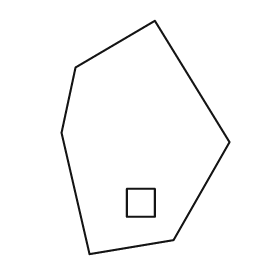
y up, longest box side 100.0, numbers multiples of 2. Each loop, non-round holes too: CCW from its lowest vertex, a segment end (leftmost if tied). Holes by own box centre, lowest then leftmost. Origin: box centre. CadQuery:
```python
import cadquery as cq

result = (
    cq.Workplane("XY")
    .moveTo(-24.0, -50.0)
    .lineTo(12.0, -44.0)
    .lineTo(36.0, -2.0)
    .lineTo(4.0, 50.0)
    .lineTo(-30.0, 30.0)
    .lineTo(-36.0, 2.0)
    .close()
    .moveTo(-8.0, -34.0)
    .lineTo(4.0, -34.0)
    .lineTo(4.0, -22.0)
    .lineTo(-8.0, -22.0)
    .close()
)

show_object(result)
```